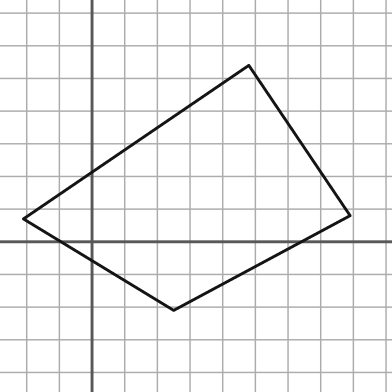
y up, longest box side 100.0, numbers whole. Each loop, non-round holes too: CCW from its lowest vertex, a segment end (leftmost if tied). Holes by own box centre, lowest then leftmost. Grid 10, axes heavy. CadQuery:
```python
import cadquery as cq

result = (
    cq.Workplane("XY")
    .moveTo(25.0, -21.0)
    .lineTo(79.0, 8.0)
    .lineTo(48.0, 54.0)
    .lineTo(-21.0, 7.0)
    .close()
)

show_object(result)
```